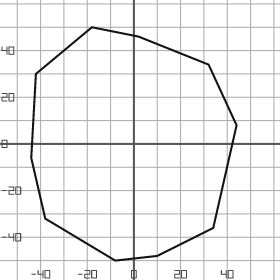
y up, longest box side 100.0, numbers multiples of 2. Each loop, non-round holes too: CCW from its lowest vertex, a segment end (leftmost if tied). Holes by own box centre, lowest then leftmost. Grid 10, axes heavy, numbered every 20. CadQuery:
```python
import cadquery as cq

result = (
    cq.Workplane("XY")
    .moveTo(-8.0, -50.0)
    .lineTo(10.0, -48.0)
    .lineTo(34.0, -36.0)
    .lineTo(44.0, 8.0)
    .lineTo(32.0, 34.0)
    .lineTo(2.0, 46.0)
    .lineTo(-18.0, 50.0)
    .lineTo(-42.0, 30.0)
    .lineTo(-44.0, -6.0)
    .lineTo(-38.0, -32.0)
    .close()
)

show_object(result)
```